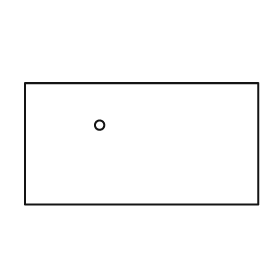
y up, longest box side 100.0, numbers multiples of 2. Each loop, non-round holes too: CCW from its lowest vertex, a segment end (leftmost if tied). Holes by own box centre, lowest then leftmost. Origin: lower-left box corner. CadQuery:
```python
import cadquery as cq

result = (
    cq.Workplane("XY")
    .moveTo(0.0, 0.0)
    .lineTo(100.0, 0.0)
    .lineTo(100.0, 52.0)
    .lineTo(0.0, 52.0)
    .close()
    .moveTo(32.0, 34.0)
    .circle(2.0)
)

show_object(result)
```